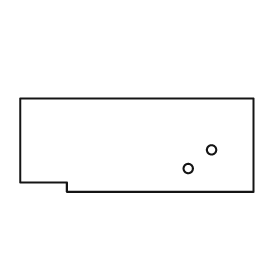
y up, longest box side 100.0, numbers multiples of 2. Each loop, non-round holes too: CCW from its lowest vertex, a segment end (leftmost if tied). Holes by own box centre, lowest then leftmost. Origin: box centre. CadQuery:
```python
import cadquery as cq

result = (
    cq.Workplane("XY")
    .moveTo(-30.0, -20.0)
    .lineTo(50.0, -20.0)
    .lineTo(50.0, 20.0)
    .lineTo(-50.0, 20.0)
    .lineTo(-50.0, -16.0)
    .lineTo(-30.0, -16.0)
    .close()
    .moveTo(22.0, -10.0)
    .circle(2.0)
    .moveTo(32.0, -2.0)
    .circle(2.0)
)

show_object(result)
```